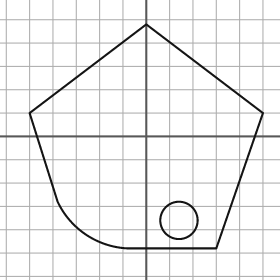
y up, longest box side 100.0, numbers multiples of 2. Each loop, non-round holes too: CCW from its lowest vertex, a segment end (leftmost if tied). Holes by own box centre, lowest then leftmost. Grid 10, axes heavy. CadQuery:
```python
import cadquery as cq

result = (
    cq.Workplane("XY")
    .moveTo(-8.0, -48.0)
    .lineTo(30.0, -48.0)
    .lineTo(50.0, 10.0)
    .lineTo(0.0, 48.0)
    .lineTo(-50.0, 10.0)
    .lineTo(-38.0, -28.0)
    .threePointArc((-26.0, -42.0), (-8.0, -48.0))
    .close()
    .moveTo(14.0, -36.0)
    .circle(8.0)
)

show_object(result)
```